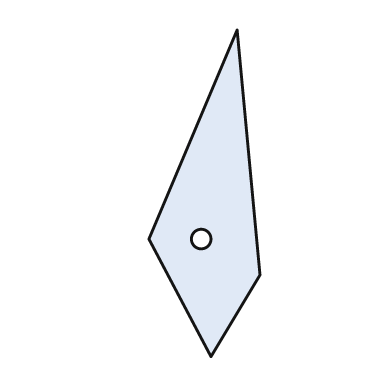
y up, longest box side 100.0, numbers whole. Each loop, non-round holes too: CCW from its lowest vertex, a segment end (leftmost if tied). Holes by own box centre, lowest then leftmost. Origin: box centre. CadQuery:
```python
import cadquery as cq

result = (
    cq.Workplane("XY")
    .moveTo(2.0, -50.0)
    .lineTo(17.0, -25.0)
    .lineTo(10.0, 50.0)
    .lineTo(-17.0, -14.0)
    .close()
    .moveTo(-1.0, -14.0)
    .circle(3.0)
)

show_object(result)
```